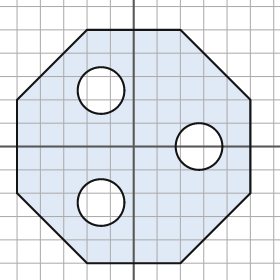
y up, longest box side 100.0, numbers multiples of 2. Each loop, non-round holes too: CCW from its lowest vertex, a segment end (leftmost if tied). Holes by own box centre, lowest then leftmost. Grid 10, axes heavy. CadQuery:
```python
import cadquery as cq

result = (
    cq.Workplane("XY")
    .moveTo(-20.0, -50.0)
    .lineTo(20.0, -50.0)
    .lineTo(50.0, -20.0)
    .lineTo(50.0, 20.0)
    .lineTo(20.0, 50.0)
    .lineTo(-20.0, 50.0)
    .lineTo(-50.0, 20.0)
    .lineTo(-50.0, -20.0)
    .close()
    .moveTo(-14.0, -24.0)
    .circle(10.0)
    .moveTo(28.0, 0.0)
    .circle(10.0)
    .moveTo(-14.0, 24.0)
    .circle(10.0)
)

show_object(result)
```